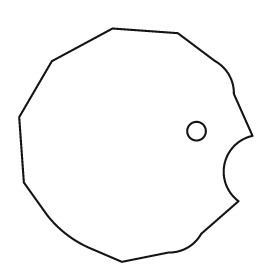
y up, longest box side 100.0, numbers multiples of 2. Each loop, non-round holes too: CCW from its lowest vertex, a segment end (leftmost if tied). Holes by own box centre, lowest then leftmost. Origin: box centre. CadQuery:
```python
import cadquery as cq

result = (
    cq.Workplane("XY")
    .moveTo(-6.0, -50.0)
    .lineTo(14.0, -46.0)
    .threePointArc((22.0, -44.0), (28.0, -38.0))
    .lineTo(44.0, -24.0)
    .threePointArc((38.0, -8.0), (50.0, 4.0))
    .lineTo(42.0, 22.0)
    .threePointArc((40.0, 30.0), (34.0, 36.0))
    .lineTo(18.0, 48.0)
    .lineTo(-10.0, 50.0)
    .lineTo(-36.0, 36.0)
    .lineTo(-50.0, 12.0)
    .lineTo(-48.0, -16.0)
    .lineTo(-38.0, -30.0)
    .threePointArc((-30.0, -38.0), (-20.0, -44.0))
    .close()
    .moveTo(26.0, 6.0)
    .circle(4.0)
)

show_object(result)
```